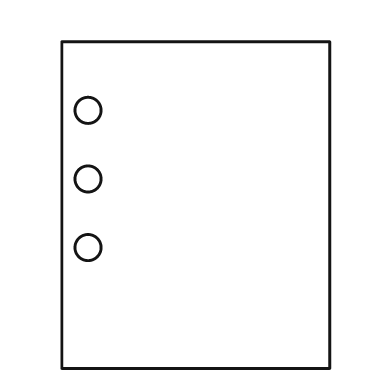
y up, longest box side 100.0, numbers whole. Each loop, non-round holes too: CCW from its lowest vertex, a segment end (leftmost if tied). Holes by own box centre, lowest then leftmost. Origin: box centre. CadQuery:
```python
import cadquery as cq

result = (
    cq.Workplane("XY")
    .moveTo(-41.0, -50.0)
    .lineTo(41.0, -50.0)
    .lineTo(41.0, 50.0)
    .lineTo(-41.0, 50.0)
    .close()
    .moveTo(-33.0, -13.0)
    .circle(4.0)
    .moveTo(-33.0, 8.0)
    .circle(4.0)
    .moveTo(-33.0, 29.0)
    .circle(4.0)
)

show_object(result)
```